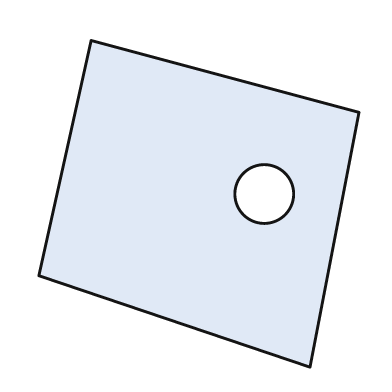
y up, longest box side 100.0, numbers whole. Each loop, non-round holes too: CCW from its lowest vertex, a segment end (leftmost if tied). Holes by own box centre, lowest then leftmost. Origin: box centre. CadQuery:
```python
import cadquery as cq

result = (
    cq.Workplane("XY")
    .moveTo(34.0, -50.0)
    .lineTo(49.0, 28.0)
    .lineTo(-33.0, 50.0)
    .lineTo(-49.0, -22.0)
    .close()
    .moveTo(20.0, 3.0)
    .circle(9.0)
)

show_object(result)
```